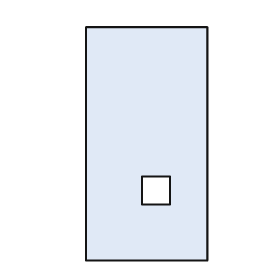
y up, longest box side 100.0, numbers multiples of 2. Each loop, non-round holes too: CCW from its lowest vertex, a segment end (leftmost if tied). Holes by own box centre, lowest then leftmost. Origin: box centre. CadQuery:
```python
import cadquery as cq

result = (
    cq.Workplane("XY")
    .moveTo(-26.0, -50.0)
    .lineTo(26.0, -50.0)
    .lineTo(26.0, 50.0)
    .lineTo(-26.0, 50.0)
    .close()
    .moveTo(-2.0, -26.0)
    .lineTo(10.0, -26.0)
    .lineTo(10.0, -14.0)
    .lineTo(-2.0, -14.0)
    .close()
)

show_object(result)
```